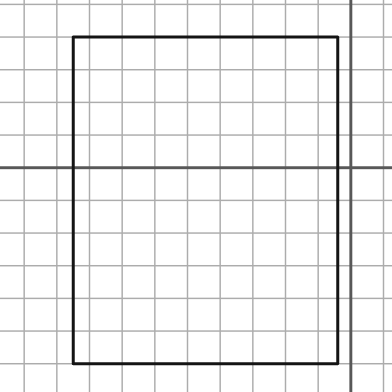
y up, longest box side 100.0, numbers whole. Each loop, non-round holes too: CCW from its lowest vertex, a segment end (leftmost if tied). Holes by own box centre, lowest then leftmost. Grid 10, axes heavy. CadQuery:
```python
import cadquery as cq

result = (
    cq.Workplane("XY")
    .moveTo(-85.0, -60.0)
    .lineTo(-4.0, -60.0)
    .lineTo(-4.0, 40.0)
    .lineTo(-85.0, 40.0)
    .close()
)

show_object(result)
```